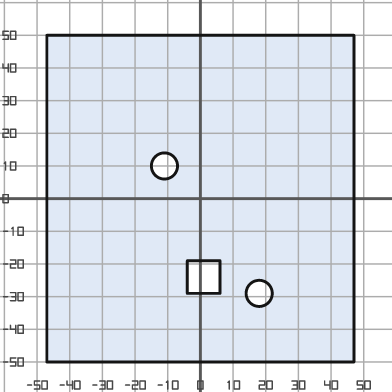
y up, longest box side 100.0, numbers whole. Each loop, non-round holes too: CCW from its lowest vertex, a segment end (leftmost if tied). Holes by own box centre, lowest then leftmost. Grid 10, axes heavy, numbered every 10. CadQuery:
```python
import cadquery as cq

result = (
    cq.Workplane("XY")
    .moveTo(-47.0, -50.0)
    .lineTo(47.0, -50.0)
    .lineTo(47.0, 50.0)
    .lineTo(-47.0, 50.0)
    .close()
    .moveTo(18.0, -29.0)
    .circle(4.0)
    .moveTo(-4.0, -29.0)
    .lineTo(6.0, -29.0)
    .lineTo(6.0, -19.0)
    .lineTo(-4.0, -19.0)
    .close()
    .moveTo(-11.0, 10.0)
    .circle(4.0)
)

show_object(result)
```